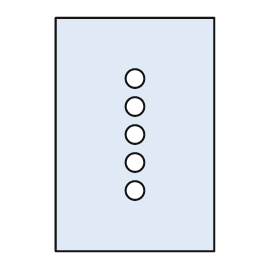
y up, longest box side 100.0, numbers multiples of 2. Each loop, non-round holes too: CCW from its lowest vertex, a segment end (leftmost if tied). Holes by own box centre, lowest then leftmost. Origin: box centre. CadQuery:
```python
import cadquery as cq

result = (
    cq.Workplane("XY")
    .moveTo(-34.0, -50.0)
    .lineTo(34.0, -50.0)
    .lineTo(34.0, 50.0)
    .lineTo(-34.0, 50.0)
    .close()
    .moveTo(0.0, -24.0)
    .circle(4.0)
    .moveTo(0.0, -12.0)
    .circle(4.0)
    .moveTo(0.0, 0.0)
    .circle(4.0)
    .moveTo(0.0, 12.0)
    .circle(4.0)
    .moveTo(0.0, 24.0)
    .circle(4.0)
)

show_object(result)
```